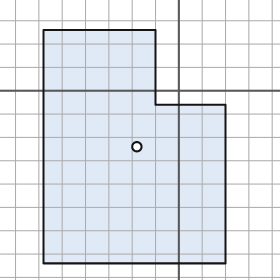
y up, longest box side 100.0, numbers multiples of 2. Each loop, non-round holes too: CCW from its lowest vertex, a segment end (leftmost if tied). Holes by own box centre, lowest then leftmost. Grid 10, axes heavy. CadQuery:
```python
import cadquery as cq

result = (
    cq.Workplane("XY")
    .moveTo(-58.0, -74.0)
    .lineTo(20.0, -74.0)
    .lineTo(20.0, -6.0)
    .lineTo(-10.0, -6.0)
    .lineTo(-10.0, 26.0)
    .lineTo(-58.0, 26.0)
    .close()
    .moveTo(-18.0, -24.0)
    .circle(2.0)
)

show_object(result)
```